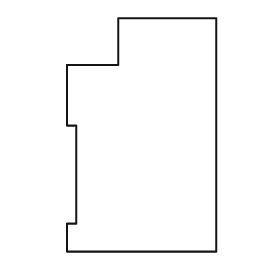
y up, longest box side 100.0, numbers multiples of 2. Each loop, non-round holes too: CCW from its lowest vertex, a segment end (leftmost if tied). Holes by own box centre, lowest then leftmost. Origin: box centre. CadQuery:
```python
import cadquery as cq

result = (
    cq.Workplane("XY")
    .moveTo(-32.0, -50.0)
    .lineTo(32.0, -50.0)
    .lineTo(32.0, 50.0)
    .lineTo(-10.0, 50.0)
    .lineTo(-10.0, 30.0)
    .lineTo(-32.0, 30.0)
    .lineTo(-32.0, 4.0)
    .lineTo(-28.0, 4.0)
    .lineTo(-28.0, -38.0)
    .lineTo(-32.0, -38.0)
    .close()
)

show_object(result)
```